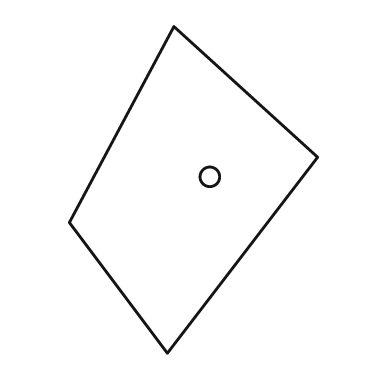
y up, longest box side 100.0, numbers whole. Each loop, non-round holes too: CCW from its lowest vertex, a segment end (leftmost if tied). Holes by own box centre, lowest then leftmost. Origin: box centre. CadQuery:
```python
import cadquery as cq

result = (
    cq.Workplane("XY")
    .moveTo(-8.0, -50.0)
    .lineTo(38.0, 10.0)
    .lineTo(-6.0, 50.0)
    .lineTo(-38.0, -10.0)
    .close()
    .moveTo(5.0, 4.0)
    .circle(3.0)
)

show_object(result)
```